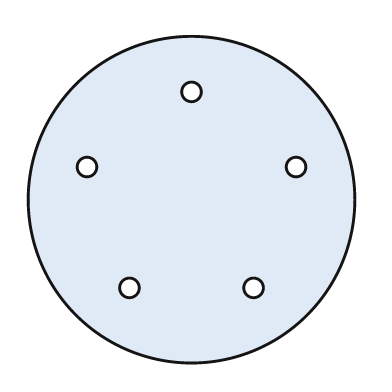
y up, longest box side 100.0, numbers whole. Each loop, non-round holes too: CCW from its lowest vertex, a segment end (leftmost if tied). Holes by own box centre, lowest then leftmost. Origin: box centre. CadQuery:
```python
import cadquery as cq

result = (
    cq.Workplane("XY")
    .moveTo(0.0, 0.0)
    .circle(50.0)
    .moveTo(-19.0, -27.0)
    .circle(3.0)
    .moveTo(19.0, -27.0)
    .circle(3.0)
    .moveTo(-32.0, 10.0)
    .circle(3.0)
    .moveTo(32.0, 10.0)
    .circle(3.0)
    .moveTo(0.0, 33.0)
    .circle(3.0)
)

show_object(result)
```